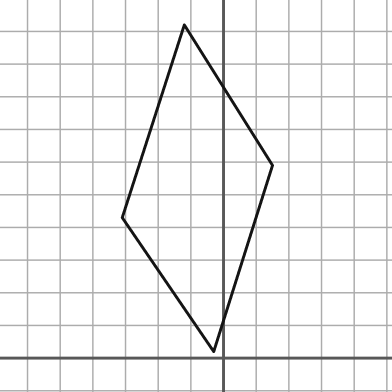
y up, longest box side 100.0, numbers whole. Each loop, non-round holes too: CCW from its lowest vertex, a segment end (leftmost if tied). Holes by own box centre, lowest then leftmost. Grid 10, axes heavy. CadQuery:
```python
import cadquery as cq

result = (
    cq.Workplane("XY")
    .moveTo(-3.0, 2.0)
    .lineTo(15.0, 59.0)
    .lineTo(-12.0, 102.0)
    .lineTo(-31.0, 43.0)
    .close()
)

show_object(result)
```